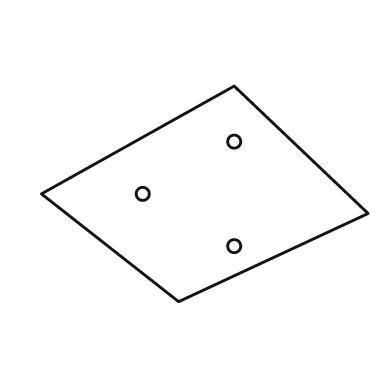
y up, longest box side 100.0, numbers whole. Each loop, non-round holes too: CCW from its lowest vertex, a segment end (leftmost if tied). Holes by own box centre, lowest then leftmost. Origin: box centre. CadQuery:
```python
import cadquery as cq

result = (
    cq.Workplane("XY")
    .moveTo(-8.0, -33.0)
    .lineTo(50.0, -6.0)
    .lineTo(9.0, 33.0)
    .lineTo(-50.0, 0.0)
    .close()
    .moveTo(9.0, -16.0)
    .circle(2.0)
    .moveTo(-19.0, 0.0)
    .circle(2.0)
    .moveTo(9.0, 16.0)
    .circle(2.0)
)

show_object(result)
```